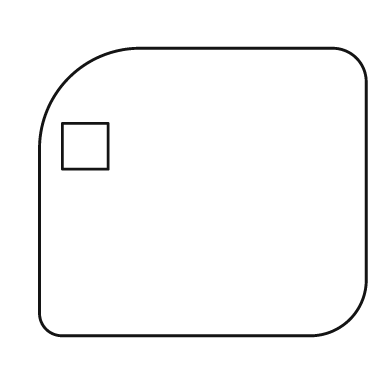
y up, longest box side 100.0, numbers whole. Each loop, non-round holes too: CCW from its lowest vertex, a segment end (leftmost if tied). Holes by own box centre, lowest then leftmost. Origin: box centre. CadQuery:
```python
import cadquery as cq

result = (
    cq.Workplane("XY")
    .moveTo(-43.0, -44.0)
    .lineTo(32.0, -44.0)
    .threePointArc((45.0, -39.0), (50.0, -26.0))
    .lineTo(50.0, 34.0)
    .threePointArc((47.0, 41.0), (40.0, 44.0))
    .lineTo(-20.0, 44.0)
    .threePointArc((-41.0, 35.0), (-50.0, 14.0))
    .lineTo(-50.0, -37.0)
    .threePointArc((-48.0, -42.0), (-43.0, -44.0))
    .close()
    .moveTo(-43.0, 7.0)
    .lineTo(-29.0, 7.0)
    .lineTo(-29.0, 21.0)
    .lineTo(-43.0, 21.0)
    .close()
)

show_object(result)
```